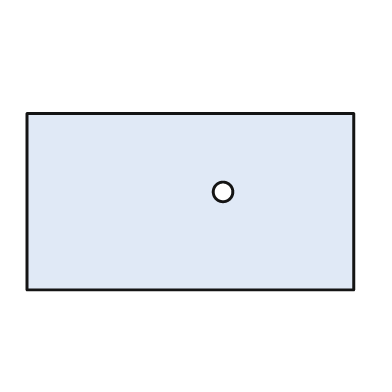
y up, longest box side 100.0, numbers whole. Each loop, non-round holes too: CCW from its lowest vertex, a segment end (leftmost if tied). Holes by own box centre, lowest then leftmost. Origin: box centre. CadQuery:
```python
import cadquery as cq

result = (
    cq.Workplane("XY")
    .moveTo(-50.0, -27.0)
    .lineTo(50.0, -27.0)
    .lineTo(50.0, 27.0)
    .lineTo(-50.0, 27.0)
    .close()
    .moveTo(10.0, 3.0)
    .circle(3.0)
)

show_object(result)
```